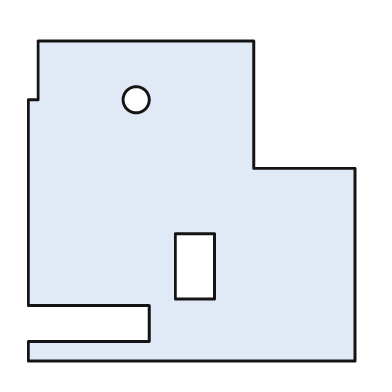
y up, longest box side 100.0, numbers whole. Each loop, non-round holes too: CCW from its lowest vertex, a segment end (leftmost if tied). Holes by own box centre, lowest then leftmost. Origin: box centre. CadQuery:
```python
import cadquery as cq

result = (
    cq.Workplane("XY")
    .moveTo(-50.0, -49.0)
    .lineTo(50.0, -49.0)
    .lineTo(50.0, 10.0)
    .lineTo(19.0, 10.0)
    .lineTo(19.0, 49.0)
    .lineTo(-47.0, 49.0)
    .lineTo(-47.0, 31.0)
    .lineTo(-50.0, 31.0)
    .lineTo(-50.0, -32.0)
    .lineTo(-13.0, -32.0)
    .lineTo(-13.0, -43.0)
    .lineTo(-50.0, -43.0)
    .close()
    .moveTo(-5.0, -30.0)
    .lineTo(7.0, -30.0)
    .lineTo(7.0, -10.0)
    .lineTo(-5.0, -10.0)
    .close()
    .moveTo(-17.0, 31.0)
    .circle(4.0)
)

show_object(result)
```